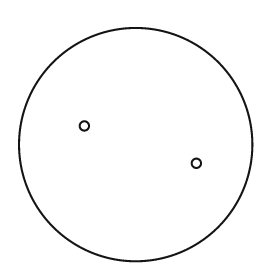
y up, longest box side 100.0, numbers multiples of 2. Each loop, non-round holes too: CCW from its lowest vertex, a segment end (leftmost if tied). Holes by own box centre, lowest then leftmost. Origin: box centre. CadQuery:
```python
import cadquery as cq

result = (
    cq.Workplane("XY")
    .moveTo(0.0, 0.0)
    .circle(50.0)
    .moveTo(26.0, -8.0)
    .circle(2.0)
    .moveTo(-22.0, 8.0)
    .circle(2.0)
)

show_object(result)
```